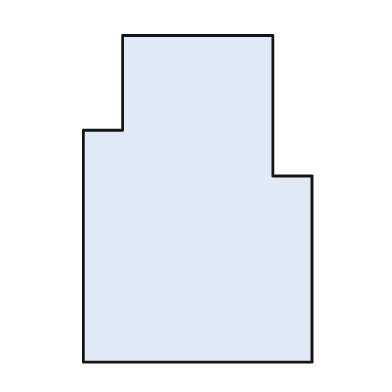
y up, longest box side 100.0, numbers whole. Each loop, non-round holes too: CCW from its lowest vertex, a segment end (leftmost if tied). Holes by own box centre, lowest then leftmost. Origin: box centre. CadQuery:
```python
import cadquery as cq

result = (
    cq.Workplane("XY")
    .moveTo(-35.0, -50.0)
    .lineTo(35.0, -50.0)
    .lineTo(35.0, 7.0)
    .lineTo(23.0, 7.0)
    .lineTo(23.0, 50.0)
    .lineTo(-23.0, 50.0)
    .lineTo(-23.0, 21.0)
    .lineTo(-35.0, 21.0)
    .close()
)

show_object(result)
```